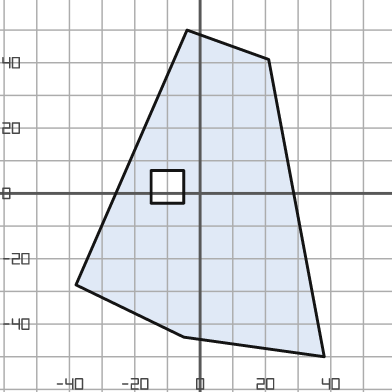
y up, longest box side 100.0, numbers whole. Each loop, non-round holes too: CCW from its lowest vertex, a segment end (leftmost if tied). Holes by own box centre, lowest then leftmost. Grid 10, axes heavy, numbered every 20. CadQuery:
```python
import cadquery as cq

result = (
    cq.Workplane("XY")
    .moveTo(38.0, -50.0)
    .lineTo(21.0, 41.0)
    .lineTo(-4.0, 50.0)
    .lineTo(-38.0, -28.0)
    .lineTo(-5.0, -44.0)
    .close()
    .moveTo(-15.0, -3.0)
    .lineTo(-5.0, -3.0)
    .lineTo(-5.0, 7.0)
    .lineTo(-15.0, 7.0)
    .close()
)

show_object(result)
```